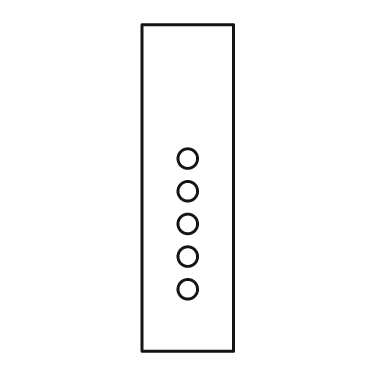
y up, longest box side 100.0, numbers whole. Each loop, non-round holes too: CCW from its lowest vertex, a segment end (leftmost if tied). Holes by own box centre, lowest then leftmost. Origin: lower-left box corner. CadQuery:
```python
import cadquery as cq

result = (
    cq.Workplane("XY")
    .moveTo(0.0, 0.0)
    .lineTo(28.0, 0.0)
    .lineTo(28.0, 100.0)
    .lineTo(0.0, 100.0)
    .close()
    .moveTo(14.0, 19.0)
    .circle(3.0)
    .moveTo(14.0, 29.0)
    .circle(3.0)
    .moveTo(14.0, 39.0)
    .circle(3.0)
    .moveTo(14.0, 49.0)
    .circle(3.0)
    .moveTo(14.0, 59.0)
    .circle(3.0)
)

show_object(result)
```